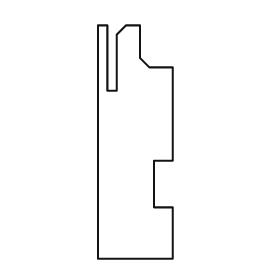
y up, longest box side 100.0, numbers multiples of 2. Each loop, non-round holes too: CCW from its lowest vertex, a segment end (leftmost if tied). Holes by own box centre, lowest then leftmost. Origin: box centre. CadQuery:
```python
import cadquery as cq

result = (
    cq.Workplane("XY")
    .moveTo(-16.0, -50.0)
    .lineTo(16.0, -50.0)
    .lineTo(16.0, -28.0)
    .lineTo(8.0, -28.0)
    .lineTo(8.0, -8.0)
    .lineTo(16.0, -8.0)
    .lineTo(16.0, 32.0)
    .lineTo(6.0, 32.0)
    .lineTo(2.0, 36.0)
    .lineTo(2.0, 50.0)
    .lineTo(-4.0, 50.0)
    .lineTo(-8.0, 46.0)
    .lineTo(-8.0, 22.0)
    .lineTo(-12.0, 22.0)
    .lineTo(-12.0, 50.0)
    .lineTo(-16.0, 50.0)
    .close()
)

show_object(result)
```